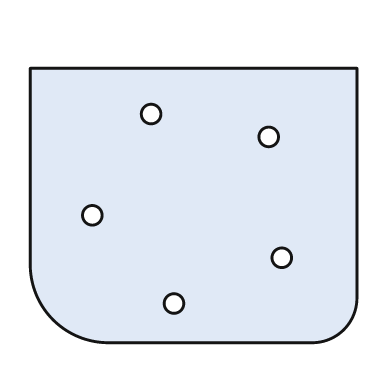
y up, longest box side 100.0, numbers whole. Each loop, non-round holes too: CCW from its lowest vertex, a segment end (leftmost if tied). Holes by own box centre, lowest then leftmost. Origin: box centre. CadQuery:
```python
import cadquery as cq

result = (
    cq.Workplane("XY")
    .moveTo(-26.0, -42.0)
    .lineTo(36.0, -42.0)
    .threePointArc((46.0, -38.0), (50.0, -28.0))
    .lineTo(50.0, 42.0)
    .lineTo(-50.0, 42.0)
    .lineTo(-50.0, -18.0)
    .threePointArc((-43.0, -35.0), (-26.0, -42.0))
    .close()
    .moveTo(-6.0, -30.0)
    .circle(3.0)
    .moveTo(27.0, -16.0)
    .circle(3.0)
    .moveTo(-31.0, -3.0)
    .circle(3.0)
    .moveTo(23.0, 21.0)
    .circle(3.0)
    .moveTo(-13.0, 28.0)
    .circle(3.0)
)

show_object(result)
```